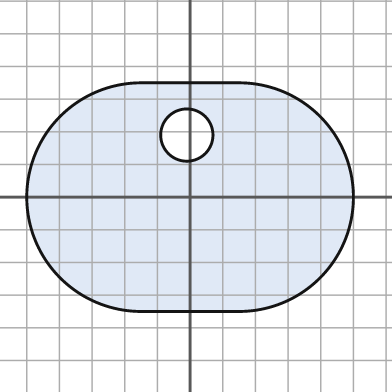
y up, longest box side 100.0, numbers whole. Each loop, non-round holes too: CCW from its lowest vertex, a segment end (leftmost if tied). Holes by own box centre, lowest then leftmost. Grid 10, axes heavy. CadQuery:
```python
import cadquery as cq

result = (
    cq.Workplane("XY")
    .moveTo(-15.0, -35.0)
    .lineTo(15.0, -35.0)
    .threePointArc((50.0, 0.0), (15.0, 35.0))
    .lineTo(-15.0, 35.0)
    .threePointArc((-50.0, 0.0), (-15.0, -35.0))
    .close()
    .moveTo(-1.0, 19.0)
    .circle(8.0)
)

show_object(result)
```